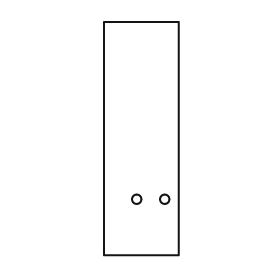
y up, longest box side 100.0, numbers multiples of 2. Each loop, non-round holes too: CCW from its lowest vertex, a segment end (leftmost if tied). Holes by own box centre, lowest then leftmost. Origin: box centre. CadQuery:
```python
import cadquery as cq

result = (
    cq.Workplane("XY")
    .moveTo(-16.0, -50.0)
    .lineTo(16.0, -50.0)
    .lineTo(16.0, 50.0)
    .lineTo(-16.0, 50.0)
    .close()
    .moveTo(-2.0, -26.0)
    .circle(2.0)
    .moveTo(10.0, -26.0)
    .circle(2.0)
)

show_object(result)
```